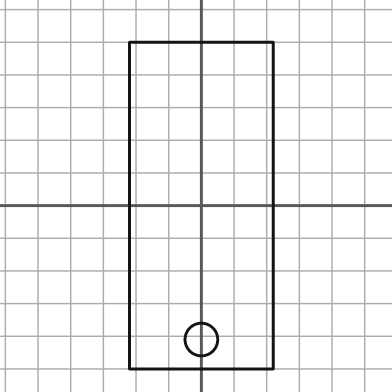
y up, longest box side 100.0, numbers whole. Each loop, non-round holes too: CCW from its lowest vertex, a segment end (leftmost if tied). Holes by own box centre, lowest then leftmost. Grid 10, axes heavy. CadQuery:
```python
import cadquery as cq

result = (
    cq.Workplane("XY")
    .moveTo(-22.0, -50.0)
    .lineTo(22.0, -50.0)
    .lineTo(22.0, 50.0)
    .lineTo(-22.0, 50.0)
    .close()
    .moveTo(0.0, -41.0)
    .circle(5.0)
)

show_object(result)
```